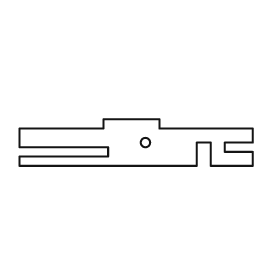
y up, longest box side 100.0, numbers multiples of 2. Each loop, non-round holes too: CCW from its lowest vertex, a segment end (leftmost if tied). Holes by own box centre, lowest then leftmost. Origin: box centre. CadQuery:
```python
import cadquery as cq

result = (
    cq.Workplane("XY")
    .moveTo(-50.0, -10.0)
    .lineTo(26.0, -10.0)
    .lineTo(26.0, 0.0)
    .lineTo(32.0, 0.0)
    .lineTo(32.0, -10.0)
    .lineTo(50.0, -10.0)
    .lineTo(50.0, -4.0)
    .lineTo(38.0, -4.0)
    .lineTo(38.0, 0.0)
    .lineTo(50.0, 0.0)
    .lineTo(50.0, 6.0)
    .lineTo(10.0, 6.0)
    .lineTo(10.0, 10.0)
    .lineTo(-14.0, 10.0)
    .lineTo(-14.0, 6.0)
    .lineTo(-50.0, 6.0)
    .lineTo(-50.0, -2.0)
    .lineTo(-12.0, -2.0)
    .lineTo(-12.0, -6.0)
    .lineTo(-50.0, -6.0)
    .close()
    .moveTo(4.0, 0.0)
    .circle(2.0)
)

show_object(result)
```